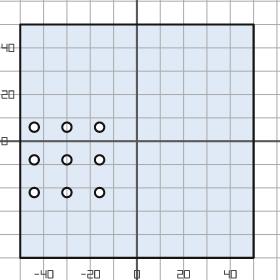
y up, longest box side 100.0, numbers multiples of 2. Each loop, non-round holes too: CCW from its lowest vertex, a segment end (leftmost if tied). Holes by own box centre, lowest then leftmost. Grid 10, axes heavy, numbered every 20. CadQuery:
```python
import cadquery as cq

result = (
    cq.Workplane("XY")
    .moveTo(-50.0, -50.0)
    .lineTo(50.0, -50.0)
    .lineTo(50.0, 50.0)
    .lineTo(-50.0, 50.0)
    .close()
    .moveTo(-44.0, -22.0)
    .circle(2.0)
    .moveTo(-30.0, -22.0)
    .circle(2.0)
    .moveTo(-16.0, -22.0)
    .circle(2.0)
    .moveTo(-44.0, -8.0)
    .circle(2.0)
    .moveTo(-30.0, -8.0)
    .circle(2.0)
    .moveTo(-16.0, -8.0)
    .circle(2.0)
    .moveTo(-44.0, 6.0)
    .circle(2.0)
    .moveTo(-30.0, 6.0)
    .circle(2.0)
    .moveTo(-16.0, 6.0)
    .circle(2.0)
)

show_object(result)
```